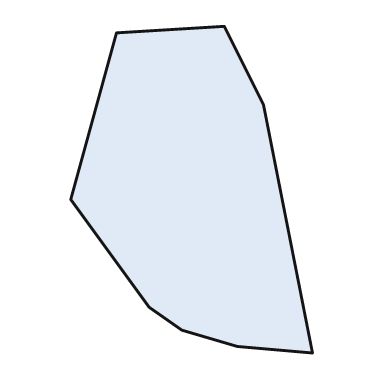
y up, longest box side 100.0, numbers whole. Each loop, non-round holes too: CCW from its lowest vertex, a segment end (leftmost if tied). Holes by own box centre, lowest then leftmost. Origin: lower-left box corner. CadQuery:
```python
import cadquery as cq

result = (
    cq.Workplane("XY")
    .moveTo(74.0, 0.0)
    .lineTo(59.0, 76.0)
    .lineTo(47.0, 100.0)
    .lineTo(14.0, 98.0)
    .lineTo(0.0, 47.0)
    .lineTo(24.0, 14.0)
    .lineTo(34.0, 7.0)
    .lineTo(51.0, 2.0)
    .close()
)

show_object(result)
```